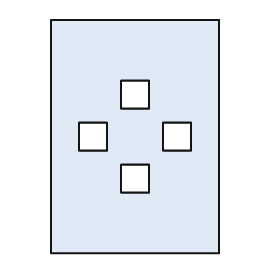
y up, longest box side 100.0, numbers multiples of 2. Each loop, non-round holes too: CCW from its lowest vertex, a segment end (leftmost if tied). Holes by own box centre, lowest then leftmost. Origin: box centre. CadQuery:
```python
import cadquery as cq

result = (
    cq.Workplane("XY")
    .moveTo(-36.0, -50.0)
    .lineTo(36.0, -50.0)
    .lineTo(36.0, 50.0)
    .lineTo(-36.0, 50.0)
    .close()
    .moveTo(-6.0, -24.0)
    .lineTo(6.0, -24.0)
    .lineTo(6.0, -12.0)
    .lineTo(-6.0, -12.0)
    .close()
    .moveTo(-24.0, -6.0)
    .lineTo(-12.0, -6.0)
    .lineTo(-12.0, 6.0)
    .lineTo(-24.0, 6.0)
    .close()
    .moveTo(12.0, -6.0)
    .lineTo(24.0, -6.0)
    .lineTo(24.0, 6.0)
    .lineTo(12.0, 6.0)
    .close()
    .moveTo(-6.0, 12.0)
    .lineTo(6.0, 12.0)
    .lineTo(6.0, 24.0)
    .lineTo(-6.0, 24.0)
    .close()
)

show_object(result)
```